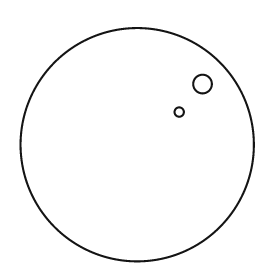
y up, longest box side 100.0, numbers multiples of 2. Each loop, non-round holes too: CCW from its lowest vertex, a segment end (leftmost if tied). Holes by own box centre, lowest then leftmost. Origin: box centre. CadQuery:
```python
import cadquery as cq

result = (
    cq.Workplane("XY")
    .moveTo(0.0, 0.0)
    .circle(50.0)
    .moveTo(18.0, 14.0)
    .circle(2.0)
    .moveTo(28.0, 26.0)
    .circle(4.0)
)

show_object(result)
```